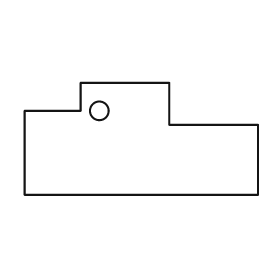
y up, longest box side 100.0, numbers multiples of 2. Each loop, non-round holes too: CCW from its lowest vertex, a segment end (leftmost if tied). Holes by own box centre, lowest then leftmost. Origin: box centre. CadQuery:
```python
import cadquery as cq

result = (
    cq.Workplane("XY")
    .moveTo(-50.0, -24.0)
    .lineTo(50.0, -24.0)
    .lineTo(50.0, 6.0)
    .lineTo(12.0, 6.0)
    .lineTo(12.0, 24.0)
    .lineTo(-26.0, 24.0)
    .lineTo(-26.0, 12.0)
    .lineTo(-50.0, 12.0)
    .close()
    .moveTo(-18.0, 12.0)
    .circle(4.0)
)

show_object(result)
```